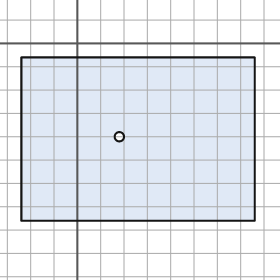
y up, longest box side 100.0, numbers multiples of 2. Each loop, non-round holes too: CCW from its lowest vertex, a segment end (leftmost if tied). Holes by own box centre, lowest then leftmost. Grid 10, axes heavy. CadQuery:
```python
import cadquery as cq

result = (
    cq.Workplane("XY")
    .moveTo(-24.0, -76.0)
    .lineTo(76.0, -76.0)
    .lineTo(76.0, -6.0)
    .lineTo(-24.0, -6.0)
    .close()
    .moveTo(18.0, -40.0)
    .circle(2.0)
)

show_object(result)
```